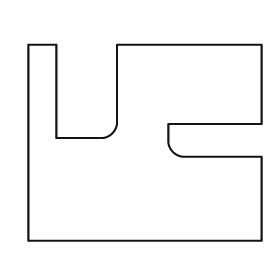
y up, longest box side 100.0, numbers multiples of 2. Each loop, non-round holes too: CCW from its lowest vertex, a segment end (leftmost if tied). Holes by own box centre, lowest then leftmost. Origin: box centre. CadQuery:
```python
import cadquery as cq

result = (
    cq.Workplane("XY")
    .moveTo(-50.0, -42.0)
    .lineTo(50.0, -42.0)
    .lineTo(50.0, -6.0)
    .lineTo(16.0, -6.0)
    .threePointArc((12.0, -4.0), (10.0, 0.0))
    .lineTo(10.0, 8.0)
    .lineTo(50.0, 8.0)
    .lineTo(50.0, 42.0)
    .lineTo(-12.0, 42.0)
    .lineTo(-12.0, 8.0)
    .threePointArc((-14.0, 4.0), (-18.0, 2.0))
    .lineTo(-38.0, 2.0)
    .lineTo(-38.0, 42.0)
    .lineTo(-50.0, 42.0)
    .close()
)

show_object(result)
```